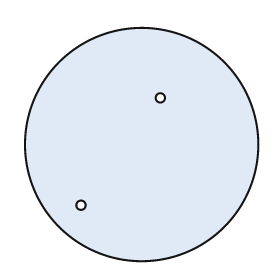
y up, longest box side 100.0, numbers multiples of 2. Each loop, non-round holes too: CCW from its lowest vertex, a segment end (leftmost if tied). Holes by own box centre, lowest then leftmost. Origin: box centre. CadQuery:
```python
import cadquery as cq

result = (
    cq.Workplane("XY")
    .moveTo(0.0, 0.0)
    .circle(50.0)
    .moveTo(-26.0, -26.0)
    .circle(2.0)
    .moveTo(8.0, 20.0)
    .circle(2.0)
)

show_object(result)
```